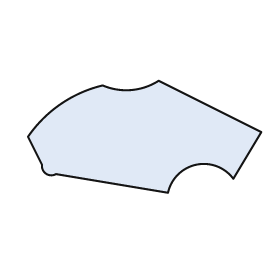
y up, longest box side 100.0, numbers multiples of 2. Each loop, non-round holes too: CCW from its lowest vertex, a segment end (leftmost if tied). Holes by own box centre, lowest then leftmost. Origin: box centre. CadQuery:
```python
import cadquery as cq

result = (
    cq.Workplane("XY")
    .moveTo(10.0, -24.0)
    .threePointArc((22.0, -12.0), (38.0, -18.0))
    .lineTo(50.0, 2.0)
    .lineTo(6.0, 24.0)
    .threePointArc((-6.0, 20.0), (-18.0, 22.0))
    .threePointArc((-36.0, 14.0), (-50.0, 0.0))
    .lineTo(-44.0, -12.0)
    .threePointArc((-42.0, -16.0), (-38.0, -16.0))
    .close()
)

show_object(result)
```